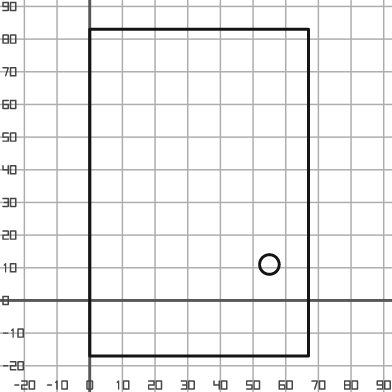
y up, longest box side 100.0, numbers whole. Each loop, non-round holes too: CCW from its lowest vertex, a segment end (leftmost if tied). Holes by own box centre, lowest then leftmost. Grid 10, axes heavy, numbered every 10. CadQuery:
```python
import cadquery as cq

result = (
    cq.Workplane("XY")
    .moveTo(0.0, -17.0)
    .lineTo(67.0, -17.0)
    .lineTo(67.0, 83.0)
    .lineTo(0.0, 83.0)
    .close()
    .moveTo(55.0, 11.0)
    .circle(3.0)
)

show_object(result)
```